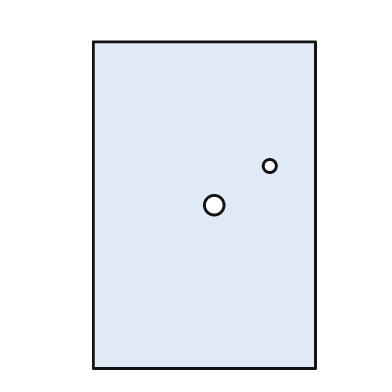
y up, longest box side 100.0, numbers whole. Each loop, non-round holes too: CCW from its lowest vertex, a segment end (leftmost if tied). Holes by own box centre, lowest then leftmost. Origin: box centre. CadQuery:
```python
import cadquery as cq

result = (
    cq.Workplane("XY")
    .moveTo(-34.0, -50.0)
    .lineTo(34.0, -50.0)
    .lineTo(34.0, 50.0)
    .lineTo(-34.0, 50.0)
    .close()
    .moveTo(3.0, 0.0)
    .circle(3.0)
    .moveTo(20.0, 12.0)
    .circle(2.0)
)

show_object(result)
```